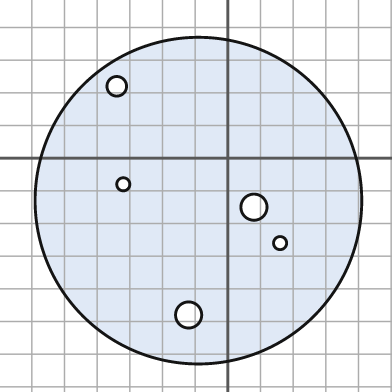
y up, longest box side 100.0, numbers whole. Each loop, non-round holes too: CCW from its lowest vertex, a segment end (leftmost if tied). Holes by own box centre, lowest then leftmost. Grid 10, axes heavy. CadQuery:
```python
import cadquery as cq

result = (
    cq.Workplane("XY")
    .moveTo(-9.0, -13.0)
    .circle(50.0)
    .moveTo(-12.0, -48.0)
    .circle(4.0)
    .moveTo(16.0, -26.0)
    .circle(2.0)
    .moveTo(8.0, -15.0)
    .circle(4.0)
    .moveTo(-32.0, -8.0)
    .circle(2.0)
    .moveTo(-34.0, 22.0)
    .circle(3.0)
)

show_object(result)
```